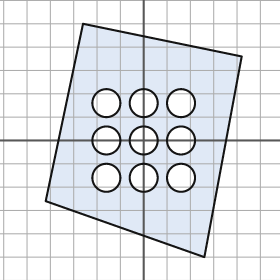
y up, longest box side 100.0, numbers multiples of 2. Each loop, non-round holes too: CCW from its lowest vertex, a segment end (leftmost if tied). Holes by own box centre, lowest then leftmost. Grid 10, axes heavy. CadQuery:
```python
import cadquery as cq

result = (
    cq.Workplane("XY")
    .moveTo(26.0, -50.0)
    .lineTo(42.0, 36.0)
    .lineTo(-26.0, 50.0)
    .lineTo(-42.0, -26.0)
    .close()
    .moveTo(-16.0, -16.0)
    .circle(6.0)
    .moveTo(0.0, -16.0)
    .circle(6.0)
    .moveTo(16.0, -16.0)
    .circle(6.0)
    .moveTo(-16.0, 0.0)
    .circle(6.0)
    .moveTo(0.0, 0.0)
    .circle(6.0)
    .moveTo(16.0, 0.0)
    .circle(6.0)
    .moveTo(-16.0, 16.0)
    .circle(6.0)
    .moveTo(0.0, 16.0)
    .circle(6.0)
    .moveTo(16.0, 16.0)
    .circle(6.0)
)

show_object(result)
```